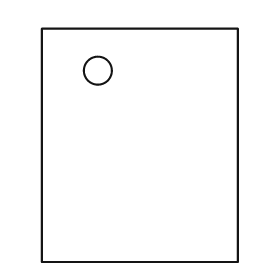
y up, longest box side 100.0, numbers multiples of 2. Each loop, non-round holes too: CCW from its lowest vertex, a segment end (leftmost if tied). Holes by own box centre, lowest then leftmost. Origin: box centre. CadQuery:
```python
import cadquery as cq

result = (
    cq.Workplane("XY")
    .moveTo(-42.0, -50.0)
    .lineTo(42.0, -50.0)
    .lineTo(42.0, 50.0)
    .lineTo(-42.0, 50.0)
    .close()
    .moveTo(-18.0, 32.0)
    .circle(6.0)
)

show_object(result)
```